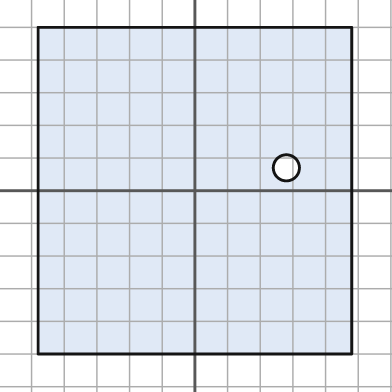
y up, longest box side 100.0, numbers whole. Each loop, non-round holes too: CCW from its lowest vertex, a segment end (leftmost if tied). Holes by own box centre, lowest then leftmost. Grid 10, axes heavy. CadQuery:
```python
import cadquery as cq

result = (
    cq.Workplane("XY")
    .moveTo(-48.0, -50.0)
    .lineTo(48.0, -50.0)
    .lineTo(48.0, 50.0)
    .lineTo(-48.0, 50.0)
    .close()
    .moveTo(28.0, 7.0)
    .circle(4.0)
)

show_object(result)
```